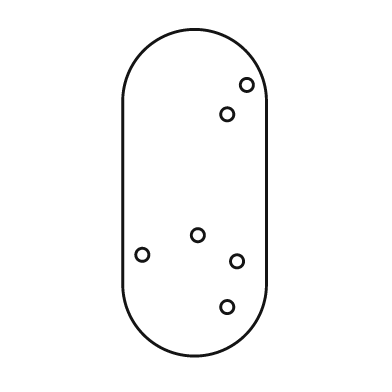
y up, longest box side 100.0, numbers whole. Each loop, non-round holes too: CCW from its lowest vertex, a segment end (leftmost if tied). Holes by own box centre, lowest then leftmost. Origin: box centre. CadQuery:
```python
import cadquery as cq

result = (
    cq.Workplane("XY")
    .moveTo(-22.0, -28.0)
    .threePointArc((0.0, -50.0), (22.0, -28.0))
    .lineTo(22.0, 28.0)
    .threePointArc((0.0, 50.0), (-22.0, 28.0))
    .close()
    .moveTo(10.0, -35.0)
    .circle(2.0)
    .moveTo(13.0, -21.0)
    .circle(2.0)
    .moveTo(-16.0, -19.0)
    .circle(2.0)
    .moveTo(1.0, -13.0)
    .circle(2.0)
    .moveTo(10.0, 24.0)
    .circle(2.0)
    .moveTo(16.0, 33.0)
    .circle(2.0)
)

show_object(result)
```